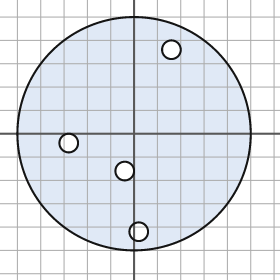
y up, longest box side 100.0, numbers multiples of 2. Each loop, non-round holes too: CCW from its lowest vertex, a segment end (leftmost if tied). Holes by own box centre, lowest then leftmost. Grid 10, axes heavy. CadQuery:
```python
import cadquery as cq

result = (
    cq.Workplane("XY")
    .moveTo(0.0, 0.0)
    .circle(50.0)
    .moveTo(2.0, -42.0)
    .circle(4.0)
    .moveTo(-4.0, -16.0)
    .circle(4.0)
    .moveTo(-28.0, -4.0)
    .circle(4.0)
    .moveTo(16.0, 36.0)
    .circle(4.0)
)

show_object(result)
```